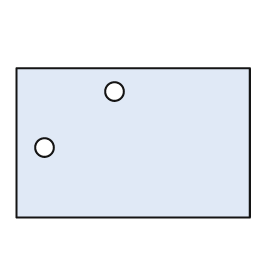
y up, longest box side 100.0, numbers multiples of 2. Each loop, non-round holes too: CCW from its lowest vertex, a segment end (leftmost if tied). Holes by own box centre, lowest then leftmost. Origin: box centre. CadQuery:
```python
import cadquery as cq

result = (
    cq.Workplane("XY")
    .moveTo(-50.0, -32.0)
    .lineTo(50.0, -32.0)
    .lineTo(50.0, 32.0)
    .lineTo(-50.0, 32.0)
    .close()
    .moveTo(-38.0, -2.0)
    .circle(4.0)
    .moveTo(-8.0, 22.0)
    .circle(4.0)
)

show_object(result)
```